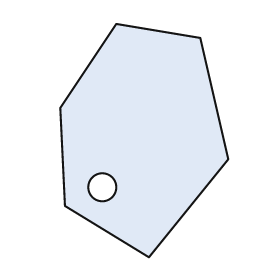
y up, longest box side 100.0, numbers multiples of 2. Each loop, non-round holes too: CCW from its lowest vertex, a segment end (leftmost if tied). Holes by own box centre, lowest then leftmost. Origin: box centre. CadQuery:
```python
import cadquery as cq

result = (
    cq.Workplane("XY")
    .moveTo(2.0, -50.0)
    .lineTo(36.0, -8.0)
    .lineTo(24.0, 44.0)
    .lineTo(-12.0, 50.0)
    .lineTo(-36.0, 14.0)
    .lineTo(-34.0, -28.0)
    .close()
    .moveTo(-18.0, -20.0)
    .circle(6.0)
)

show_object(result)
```